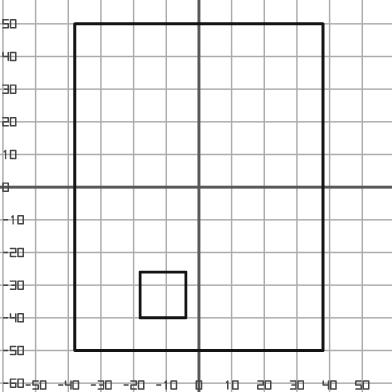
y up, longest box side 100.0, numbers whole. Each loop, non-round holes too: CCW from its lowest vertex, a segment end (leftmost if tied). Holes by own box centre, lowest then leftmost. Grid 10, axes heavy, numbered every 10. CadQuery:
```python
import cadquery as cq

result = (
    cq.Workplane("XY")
    .moveTo(-38.0, -50.0)
    .lineTo(38.0, -50.0)
    .lineTo(38.0, 50.0)
    .lineTo(-38.0, 50.0)
    .close()
    .moveTo(-18.0, -40.0)
    .lineTo(-4.0, -40.0)
    .lineTo(-4.0, -26.0)
    .lineTo(-18.0, -26.0)
    .close()
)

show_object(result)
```